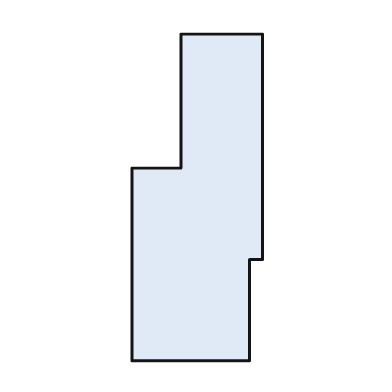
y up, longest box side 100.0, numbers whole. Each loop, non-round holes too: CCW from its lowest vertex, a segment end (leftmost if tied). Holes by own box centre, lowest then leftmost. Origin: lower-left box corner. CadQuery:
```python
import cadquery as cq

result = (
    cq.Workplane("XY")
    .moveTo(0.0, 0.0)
    .lineTo(36.0, 0.0)
    .lineTo(36.0, 31.0)
    .lineTo(40.0, 31.0)
    .lineTo(40.0, 100.0)
    .lineTo(15.0, 100.0)
    .lineTo(15.0, 59.0)
    .lineTo(0.0, 59.0)
    .close()
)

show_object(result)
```